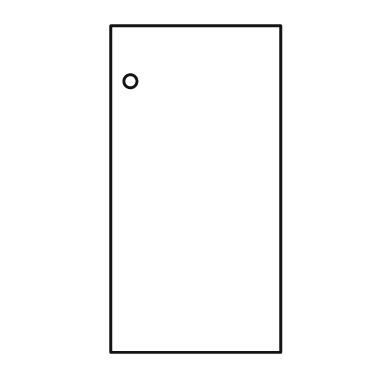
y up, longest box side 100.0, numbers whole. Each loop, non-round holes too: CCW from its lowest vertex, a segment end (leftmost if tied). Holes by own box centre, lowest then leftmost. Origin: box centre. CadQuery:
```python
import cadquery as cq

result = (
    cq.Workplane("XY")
    .moveTo(-26.0, -50.0)
    .lineTo(26.0, -50.0)
    .lineTo(26.0, 50.0)
    .lineTo(-26.0, 50.0)
    .close()
    .moveTo(-20.0, 33.0)
    .circle(2.0)
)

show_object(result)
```